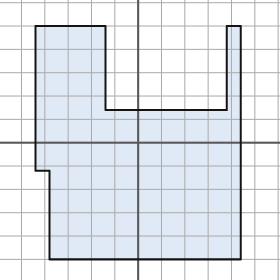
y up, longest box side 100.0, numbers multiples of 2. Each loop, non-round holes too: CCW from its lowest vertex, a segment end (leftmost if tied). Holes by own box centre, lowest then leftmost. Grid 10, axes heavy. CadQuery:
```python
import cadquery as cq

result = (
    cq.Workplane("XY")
    .moveTo(-38.0, -50.0)
    .lineTo(44.0, -50.0)
    .lineTo(44.0, 50.0)
    .lineTo(38.0, 50.0)
    .lineTo(38.0, 14.0)
    .lineTo(-14.0, 14.0)
    .lineTo(-14.0, 50.0)
    .lineTo(-44.0, 50.0)
    .lineTo(-44.0, -12.0)
    .lineTo(-38.0, -12.0)
    .close()
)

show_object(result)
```